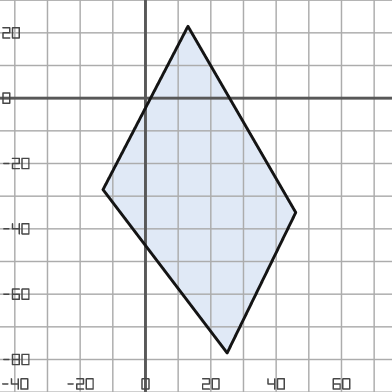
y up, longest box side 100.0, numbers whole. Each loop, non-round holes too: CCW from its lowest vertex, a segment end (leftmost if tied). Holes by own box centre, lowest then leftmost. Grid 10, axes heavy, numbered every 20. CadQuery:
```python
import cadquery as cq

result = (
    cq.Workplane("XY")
    .moveTo(25.0, -78.0)
    .lineTo(46.0, -35.0)
    .lineTo(13.0, 22.0)
    .lineTo(-13.0, -28.0)
    .close()
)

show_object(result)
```